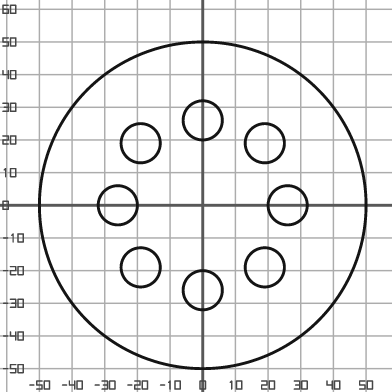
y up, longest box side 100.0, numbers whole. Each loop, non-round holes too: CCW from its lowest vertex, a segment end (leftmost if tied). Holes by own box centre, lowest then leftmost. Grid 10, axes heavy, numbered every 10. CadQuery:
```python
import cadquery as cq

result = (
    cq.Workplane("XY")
    .moveTo(0.0, 0.0)
    .circle(50.0)
    .moveTo(0.0, -26.0)
    .circle(6.0)
    .moveTo(-19.0, -19.0)
    .circle(6.0)
    .moveTo(19.0, -19.0)
    .circle(6.0)
    .moveTo(-26.0, 0.0)
    .circle(6.0)
    .moveTo(26.0, 0.0)
    .circle(6.0)
    .moveTo(-19.0, 19.0)
    .circle(6.0)
    .moveTo(19.0, 19.0)
    .circle(6.0)
    .moveTo(0.0, 26.0)
    .circle(6.0)
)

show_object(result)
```